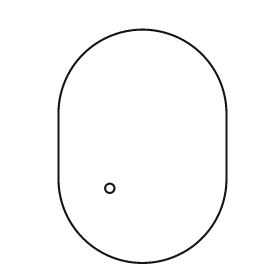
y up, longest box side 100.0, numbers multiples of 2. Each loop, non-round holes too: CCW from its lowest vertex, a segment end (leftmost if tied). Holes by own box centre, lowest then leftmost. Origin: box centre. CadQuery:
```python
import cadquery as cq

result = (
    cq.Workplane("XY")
    .moveTo(-36.0, -14.0)
    .threePointArc((0.0, -50.0), (36.0, -14.0))
    .lineTo(36.0, 14.0)
    .threePointArc((0.0, 50.0), (-36.0, 14.0))
    .close()
    .moveTo(-14.0, -18.0)
    .circle(2.0)
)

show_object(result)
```